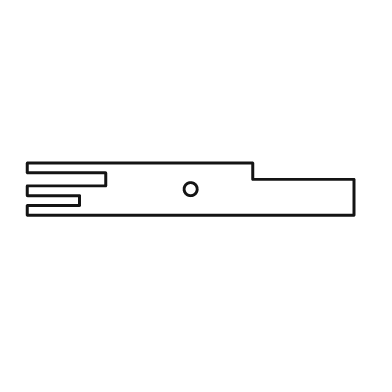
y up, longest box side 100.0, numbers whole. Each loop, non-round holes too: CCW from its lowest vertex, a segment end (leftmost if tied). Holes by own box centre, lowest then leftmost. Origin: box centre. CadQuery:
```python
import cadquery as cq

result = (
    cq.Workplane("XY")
    .moveTo(-50.0, -8.0)
    .lineTo(50.0, -8.0)
    .lineTo(50.0, 3.0)
    .lineTo(19.0, 3.0)
    .lineTo(19.0, 8.0)
    .lineTo(-50.0, 8.0)
    .lineTo(-50.0, 5.0)
    .lineTo(-26.0, 5.0)
    .lineTo(-26.0, 1.0)
    .lineTo(-50.0, 1.0)
    .lineTo(-50.0, -2.0)
    .lineTo(-34.0, -2.0)
    .lineTo(-34.0, -5.0)
    .lineTo(-50.0, -5.0)
    .close()
    .moveTo(0.0, 0.0)
    .circle(2.0)
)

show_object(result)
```